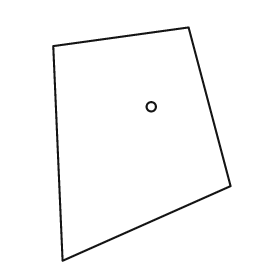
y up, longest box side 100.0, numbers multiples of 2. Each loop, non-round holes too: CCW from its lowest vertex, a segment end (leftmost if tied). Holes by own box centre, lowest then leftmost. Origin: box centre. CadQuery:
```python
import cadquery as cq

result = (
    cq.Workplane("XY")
    .moveTo(-34.0, -50.0)
    .lineTo(38.0, -18.0)
    .lineTo(20.0, 50.0)
    .lineTo(-38.0, 42.0)
    .close()
    .moveTo(4.0, 16.0)
    .circle(2.0)
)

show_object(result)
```